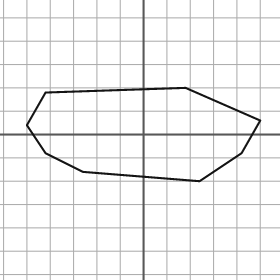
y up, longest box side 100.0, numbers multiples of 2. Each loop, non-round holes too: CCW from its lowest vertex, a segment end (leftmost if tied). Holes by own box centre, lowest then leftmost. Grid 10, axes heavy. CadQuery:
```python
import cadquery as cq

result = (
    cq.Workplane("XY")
    .moveTo(24.0, -20.0)
    .lineTo(42.0, -8.0)
    .lineTo(50.0, 6.0)
    .lineTo(18.0, 20.0)
    .lineTo(-42.0, 18.0)
    .lineTo(-50.0, 4.0)
    .lineTo(-42.0, -8.0)
    .lineTo(-26.0, -16.0)
    .close()
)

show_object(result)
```